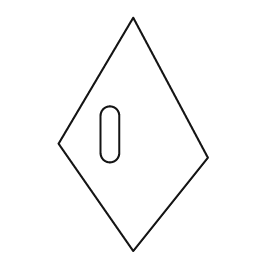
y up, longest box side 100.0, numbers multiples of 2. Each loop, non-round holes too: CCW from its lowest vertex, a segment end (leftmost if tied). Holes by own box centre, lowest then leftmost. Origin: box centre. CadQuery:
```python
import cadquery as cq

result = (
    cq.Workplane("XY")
    .moveTo(0.0, -50.0)
    .lineTo(32.0, -10.0)
    .lineTo(0.0, 50.0)
    .lineTo(-32.0, -4.0)
    .close()
    .moveTo(-14.0, -8.0)
    .threePointArc((-10.0, -12.0), (-6.0, -8.0))
    .lineTo(-6.0, 8.0)
    .threePointArc((-10.0, 12.0), (-14.0, 8.0))
    .close()
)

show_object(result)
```